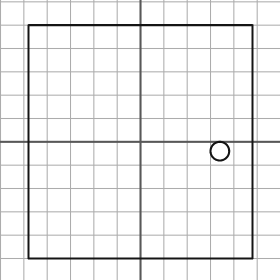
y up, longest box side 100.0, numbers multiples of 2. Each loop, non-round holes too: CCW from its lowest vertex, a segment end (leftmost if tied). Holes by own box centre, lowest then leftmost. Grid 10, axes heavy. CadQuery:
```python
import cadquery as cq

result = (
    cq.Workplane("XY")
    .moveTo(-48.0, -50.0)
    .lineTo(48.0, -50.0)
    .lineTo(48.0, 50.0)
    .lineTo(-48.0, 50.0)
    .close()
    .moveTo(34.0, -4.0)
    .circle(4.0)
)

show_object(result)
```